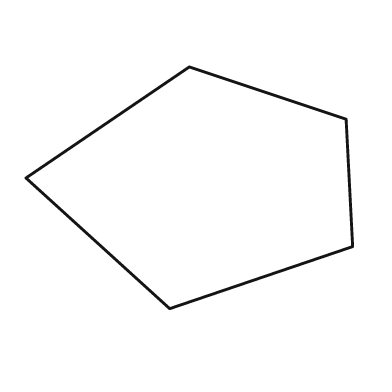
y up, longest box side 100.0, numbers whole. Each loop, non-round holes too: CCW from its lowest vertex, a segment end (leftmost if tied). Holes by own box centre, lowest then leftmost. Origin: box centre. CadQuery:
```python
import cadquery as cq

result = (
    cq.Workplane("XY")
    .moveTo(-6.0, -37.0)
    .lineTo(50.0, -18.0)
    .lineTo(48.0, 21.0)
    .lineTo(0.0, 37.0)
    .lineTo(-50.0, 3.0)
    .close()
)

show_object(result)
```